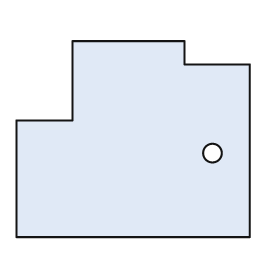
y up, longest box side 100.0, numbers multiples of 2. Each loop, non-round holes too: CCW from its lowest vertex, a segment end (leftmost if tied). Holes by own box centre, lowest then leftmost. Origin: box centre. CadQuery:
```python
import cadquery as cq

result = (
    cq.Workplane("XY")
    .moveTo(-50.0, -42.0)
    .lineTo(50.0, -42.0)
    .lineTo(50.0, 32.0)
    .lineTo(22.0, 32.0)
    .lineTo(22.0, 42.0)
    .lineTo(-26.0, 42.0)
    .lineTo(-26.0, 8.0)
    .lineTo(-50.0, 8.0)
    .close()
    .moveTo(34.0, -6.0)
    .circle(4.0)
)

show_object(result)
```